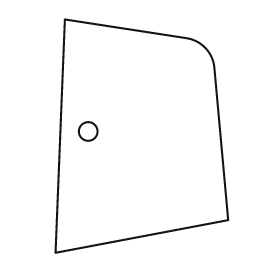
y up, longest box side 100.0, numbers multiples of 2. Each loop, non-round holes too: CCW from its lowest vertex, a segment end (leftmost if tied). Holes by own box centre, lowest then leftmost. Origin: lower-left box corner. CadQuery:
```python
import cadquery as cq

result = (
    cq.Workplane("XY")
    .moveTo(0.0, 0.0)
    .lineTo(74.0, 14.0)
    .lineTo(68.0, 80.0)
    .threePointArc((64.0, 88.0), (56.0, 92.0))
    .lineTo(4.0, 100.0)
    .close()
    .moveTo(14.0, 52.0)
    .circle(4.0)
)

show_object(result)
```